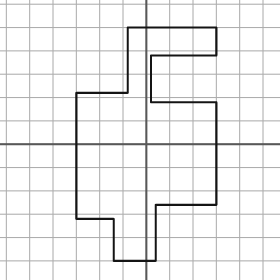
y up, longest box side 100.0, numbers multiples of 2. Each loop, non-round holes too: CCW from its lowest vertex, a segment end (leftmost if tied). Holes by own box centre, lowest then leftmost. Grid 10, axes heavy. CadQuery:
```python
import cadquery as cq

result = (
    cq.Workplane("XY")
    .moveTo(-14.0, -50.0)
    .lineTo(4.0, -50.0)
    .lineTo(4.0, -26.0)
    .lineTo(30.0, -26.0)
    .lineTo(30.0, 18.0)
    .lineTo(2.0, 18.0)
    .lineTo(2.0, 38.0)
    .lineTo(30.0, 38.0)
    .lineTo(30.0, 50.0)
    .lineTo(-8.0, 50.0)
    .lineTo(-8.0, 22.0)
    .lineTo(-30.0, 22.0)
    .lineTo(-30.0, -32.0)
    .lineTo(-14.0, -32.0)
    .close()
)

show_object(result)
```